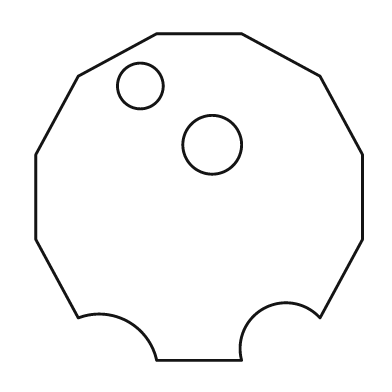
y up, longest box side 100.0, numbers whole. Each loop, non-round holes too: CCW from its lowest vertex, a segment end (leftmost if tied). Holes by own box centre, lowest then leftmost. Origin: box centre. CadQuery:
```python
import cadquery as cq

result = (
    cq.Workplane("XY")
    .moveTo(-13.0, -50.0)
    .lineTo(13.0, -50.0)
    .threePointArc((20.0, -34.0), (37.0, -37.0))
    .lineTo(50.0, -13.0)
    .lineTo(50.0, 13.0)
    .lineTo(37.0, 37.0)
    .lineTo(13.0, 50.0)
    .lineTo(-13.0, 50.0)
    .lineTo(-37.0, 37.0)
    .lineTo(-50.0, 13.0)
    .lineTo(-50.0, -13.0)
    .lineTo(-37.0, -37.0)
    .threePointArc((-22.0, -38.0), (-13.0, -50.0))
    .close()
    .moveTo(4.0, 16.0)
    .circle(9.0)
    .moveTo(-18.0, 34.0)
    .circle(7.0)
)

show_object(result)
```